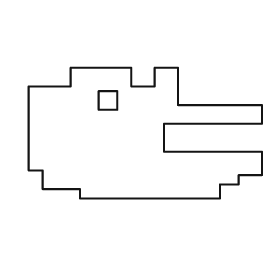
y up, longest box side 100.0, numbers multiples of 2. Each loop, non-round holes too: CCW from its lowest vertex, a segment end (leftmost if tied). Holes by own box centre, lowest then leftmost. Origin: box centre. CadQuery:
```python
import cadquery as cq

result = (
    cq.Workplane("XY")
    .moveTo(-28.0, -28.0)
    .lineTo(32.0, -28.0)
    .lineTo(32.0, -22.0)
    .lineTo(40.0, -22.0)
    .lineTo(40.0, -18.0)
    .lineTo(50.0, -18.0)
    .lineTo(50.0, -8.0)
    .lineTo(8.0, -8.0)
    .lineTo(8.0, 4.0)
    .lineTo(50.0, 4.0)
    .lineTo(50.0, 12.0)
    .lineTo(14.0, 12.0)
    .lineTo(14.0, 28.0)
    .lineTo(4.0, 28.0)
    .lineTo(4.0, 20.0)
    .lineTo(-6.0, 20.0)
    .lineTo(-6.0, 28.0)
    .lineTo(-32.0, 28.0)
    .lineTo(-32.0, 20.0)
    .lineTo(-50.0, 20.0)
    .lineTo(-50.0, -16.0)
    .lineTo(-44.0, -16.0)
    .lineTo(-44.0, -24.0)
    .lineTo(-28.0, -24.0)
    .close()
    .moveTo(-20.0, 10.0)
    .lineTo(-12.0, 10.0)
    .lineTo(-12.0, 18.0)
    .lineTo(-20.0, 18.0)
    .close()
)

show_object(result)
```